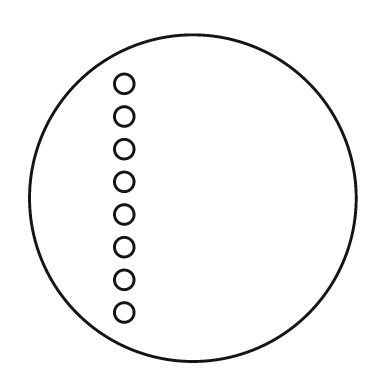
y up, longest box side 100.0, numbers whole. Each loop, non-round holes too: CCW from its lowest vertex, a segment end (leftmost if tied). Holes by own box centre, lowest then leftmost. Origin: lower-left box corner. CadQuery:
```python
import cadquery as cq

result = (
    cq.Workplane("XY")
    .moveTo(50.0, 50.0)
    .circle(50.0)
    .moveTo(29.0, 15.0)
    .circle(3.0)
    .moveTo(29.0, 25.0)
    .circle(3.0)
    .moveTo(29.0, 35.0)
    .circle(3.0)
    .moveTo(29.0, 45.0)
    .circle(3.0)
    .moveTo(29.0, 55.0)
    .circle(3.0)
    .moveTo(29.0, 65.0)
    .circle(3.0)
    .moveTo(29.0, 75.0)
    .circle(3.0)
    .moveTo(29.0, 85.0)
    .circle(3.0)
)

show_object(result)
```